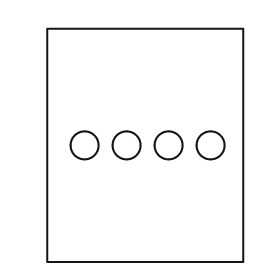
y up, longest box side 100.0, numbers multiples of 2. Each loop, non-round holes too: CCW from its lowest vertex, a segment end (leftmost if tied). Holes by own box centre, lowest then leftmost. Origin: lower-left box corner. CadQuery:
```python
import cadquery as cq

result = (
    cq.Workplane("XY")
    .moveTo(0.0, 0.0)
    .lineTo(84.0, 0.0)
    .lineTo(84.0, 100.0)
    .lineTo(0.0, 100.0)
    .close()
    .moveTo(16.0, 50.0)
    .circle(6.0)
    .moveTo(34.0, 50.0)
    .circle(6.0)
    .moveTo(52.0, 50.0)
    .circle(6.0)
    .moveTo(70.0, 50.0)
    .circle(6.0)
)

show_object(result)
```